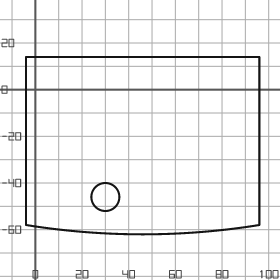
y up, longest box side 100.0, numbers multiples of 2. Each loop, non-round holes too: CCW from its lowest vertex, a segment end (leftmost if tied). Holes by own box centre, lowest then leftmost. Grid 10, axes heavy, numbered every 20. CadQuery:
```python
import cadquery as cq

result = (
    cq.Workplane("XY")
    .moveTo(-4.0, -58.0)
    .threePointArc((46.0, -62.0), (96.0, -58.0))
    .lineTo(96.0, 14.0)
    .lineTo(-4.0, 14.0)
    .close()
    .moveTo(30.0, -46.0)
    .circle(6.0)
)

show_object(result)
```